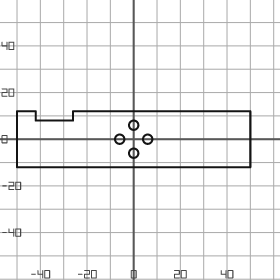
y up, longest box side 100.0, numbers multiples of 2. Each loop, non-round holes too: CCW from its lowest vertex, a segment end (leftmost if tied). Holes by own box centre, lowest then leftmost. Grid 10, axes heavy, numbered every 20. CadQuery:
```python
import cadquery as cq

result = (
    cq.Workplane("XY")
    .moveTo(-50.0, -12.0)
    .lineTo(50.0, -12.0)
    .lineTo(50.0, 12.0)
    .lineTo(-26.0, 12.0)
    .lineTo(-26.0, 8.0)
    .lineTo(-42.0, 8.0)
    .lineTo(-42.0, 12.0)
    .lineTo(-50.0, 12.0)
    .close()
    .moveTo(0.0, -6.0)
    .circle(2.0)
    .moveTo(-6.0, 0.0)
    .circle(2.0)
    .moveTo(6.0, 0.0)
    .circle(2.0)
    .moveTo(0.0, 6.0)
    .circle(2.0)
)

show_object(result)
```